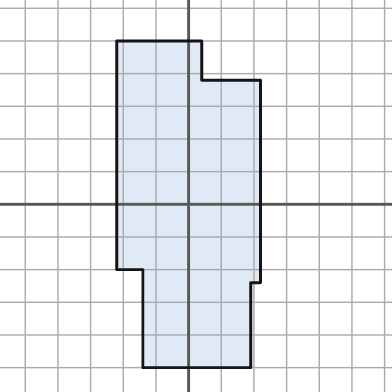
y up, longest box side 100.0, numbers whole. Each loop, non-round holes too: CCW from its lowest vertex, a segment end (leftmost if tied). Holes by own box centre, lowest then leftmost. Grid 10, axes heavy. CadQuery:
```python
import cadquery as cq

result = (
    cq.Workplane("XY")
    .moveTo(-14.0, -50.0)
    .lineTo(19.0, -50.0)
    .lineTo(19.0, -24.0)
    .lineTo(22.0, -24.0)
    .lineTo(22.0, 38.0)
    .lineTo(4.0, 38.0)
    .lineTo(4.0, 50.0)
    .lineTo(-22.0, 50.0)
    .lineTo(-22.0, -20.0)
    .lineTo(-14.0, -20.0)
    .close()
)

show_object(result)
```